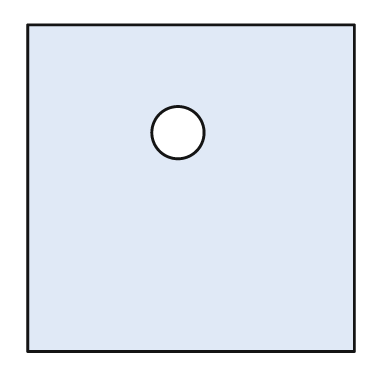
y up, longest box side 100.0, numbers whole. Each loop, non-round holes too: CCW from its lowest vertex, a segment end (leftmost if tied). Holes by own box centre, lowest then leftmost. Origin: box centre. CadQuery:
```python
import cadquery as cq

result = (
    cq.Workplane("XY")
    .moveTo(-50.0, -50.0)
    .lineTo(50.0, -50.0)
    .lineTo(50.0, 50.0)
    .lineTo(-50.0, 50.0)
    .close()
    .moveTo(-4.0, 17.0)
    .circle(8.0)
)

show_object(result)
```